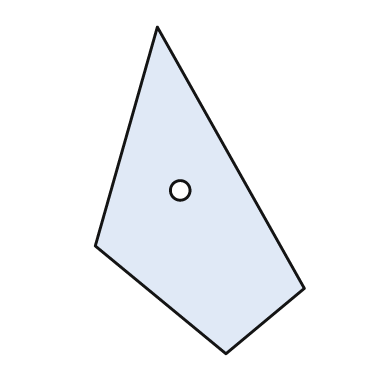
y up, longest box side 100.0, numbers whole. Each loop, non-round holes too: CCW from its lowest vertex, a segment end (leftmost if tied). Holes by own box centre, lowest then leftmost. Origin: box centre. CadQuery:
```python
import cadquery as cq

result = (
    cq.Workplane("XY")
    .moveTo(8.0, -50.0)
    .lineTo(32.0, -30.0)
    .lineTo(-13.0, 50.0)
    .lineTo(-32.0, -17.0)
    .close()
    .moveTo(-6.0, 0.0)
    .circle(3.0)
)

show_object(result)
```